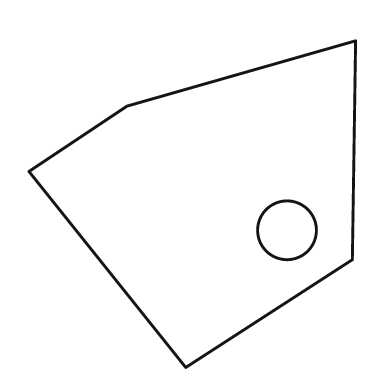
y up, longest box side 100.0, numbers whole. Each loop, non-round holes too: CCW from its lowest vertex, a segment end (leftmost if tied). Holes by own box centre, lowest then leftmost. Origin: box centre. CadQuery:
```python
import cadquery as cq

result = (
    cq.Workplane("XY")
    .moveTo(-2.0, -50.0)
    .lineTo(49.0, -17.0)
    .lineTo(50.0, 50.0)
    .lineTo(-20.0, 30.0)
    .lineTo(-50.0, 10.0)
    .close()
    .moveTo(29.0, -8.0)
    .circle(9.0)
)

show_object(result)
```